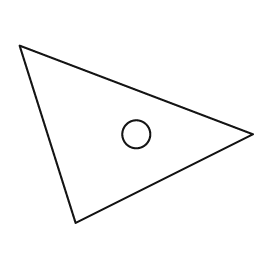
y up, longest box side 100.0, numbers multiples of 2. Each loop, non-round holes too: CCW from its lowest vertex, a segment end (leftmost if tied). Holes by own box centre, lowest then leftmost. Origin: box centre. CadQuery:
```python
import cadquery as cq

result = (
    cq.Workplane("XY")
    .moveTo(-26.0, -38.0)
    .lineTo(50.0, 0.0)
    .lineTo(-50.0, 38.0)
    .close()
    .moveTo(0.0, 0.0)
    .circle(6.0)
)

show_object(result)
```